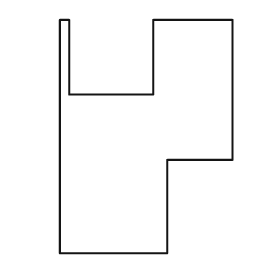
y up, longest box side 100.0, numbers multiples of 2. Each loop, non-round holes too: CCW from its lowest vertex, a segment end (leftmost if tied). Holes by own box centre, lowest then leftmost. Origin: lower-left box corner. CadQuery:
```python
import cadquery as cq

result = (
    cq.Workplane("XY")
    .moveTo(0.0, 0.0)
    .lineTo(46.0, 0.0)
    .lineTo(46.0, 40.0)
    .lineTo(74.0, 40.0)
    .lineTo(74.0, 100.0)
    .lineTo(40.0, 100.0)
    .lineTo(40.0, 68.0)
    .lineTo(4.0, 68.0)
    .lineTo(4.0, 100.0)
    .lineTo(0.0, 100.0)
    .close()
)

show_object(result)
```